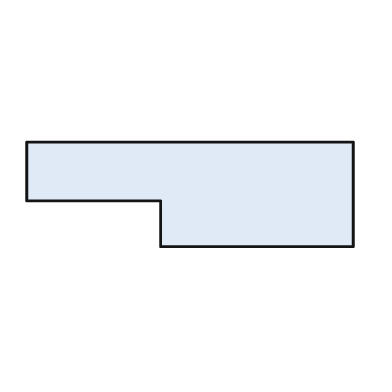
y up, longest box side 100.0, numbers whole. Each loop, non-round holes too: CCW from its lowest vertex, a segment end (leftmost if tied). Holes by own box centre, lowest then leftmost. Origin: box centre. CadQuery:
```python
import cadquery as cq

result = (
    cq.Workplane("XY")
    .moveTo(-9.0, -16.0)
    .lineTo(50.0, -16.0)
    .lineTo(50.0, 16.0)
    .lineTo(-50.0, 16.0)
    .lineTo(-50.0, -2.0)
    .lineTo(-9.0, -2.0)
    .close()
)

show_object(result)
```